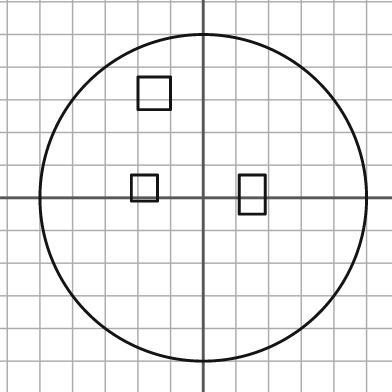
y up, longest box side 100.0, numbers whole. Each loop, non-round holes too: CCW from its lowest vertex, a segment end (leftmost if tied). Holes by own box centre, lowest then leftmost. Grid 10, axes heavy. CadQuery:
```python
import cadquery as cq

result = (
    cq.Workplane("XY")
    .moveTo(0.0, 0.0)
    .circle(50.0)
    .moveTo(11.0, -5.0)
    .lineTo(19.0, -5.0)
    .lineTo(19.0, 7.0)
    .lineTo(11.0, 7.0)
    .close()
    .moveTo(-22.0, -1.0)
    .lineTo(-14.0, -1.0)
    .lineTo(-14.0, 7.0)
    .lineTo(-22.0, 7.0)
    .close()
    .moveTo(-20.0, 27.0)
    .lineTo(-10.0, 27.0)
    .lineTo(-10.0, 37.0)
    .lineTo(-20.0, 37.0)
    .close()
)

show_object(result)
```